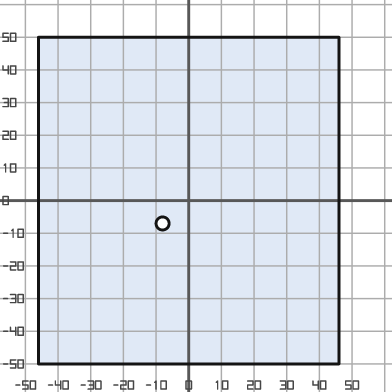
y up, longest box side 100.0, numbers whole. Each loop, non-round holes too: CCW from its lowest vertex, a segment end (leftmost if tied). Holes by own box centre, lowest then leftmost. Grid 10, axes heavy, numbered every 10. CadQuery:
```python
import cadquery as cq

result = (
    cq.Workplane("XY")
    .moveTo(-46.0, -50.0)
    .lineTo(46.0, -50.0)
    .lineTo(46.0, 50.0)
    .lineTo(-46.0, 50.0)
    .close()
    .moveTo(-8.0, -7.0)
    .circle(2.0)
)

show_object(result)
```